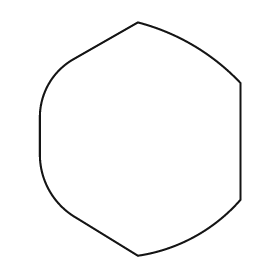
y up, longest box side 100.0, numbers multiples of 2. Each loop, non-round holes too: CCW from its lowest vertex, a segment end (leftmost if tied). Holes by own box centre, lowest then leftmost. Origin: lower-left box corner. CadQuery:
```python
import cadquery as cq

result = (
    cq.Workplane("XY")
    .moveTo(42.0, 0.0)
    .threePointArc((66.0, 8.0), (86.0, 24.0))
    .lineTo(86.0, 74.0)
    .threePointArc((66.0, 90.0), (42.0, 100.0))
    .lineTo(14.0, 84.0)
    .threePointArc((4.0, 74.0), (0.0, 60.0))
    .lineTo(0.0, 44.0)
    .threePointArc((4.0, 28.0), (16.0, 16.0))
    .close()
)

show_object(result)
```